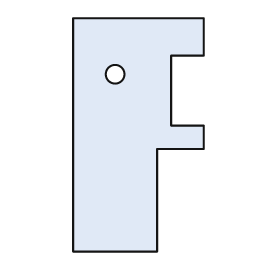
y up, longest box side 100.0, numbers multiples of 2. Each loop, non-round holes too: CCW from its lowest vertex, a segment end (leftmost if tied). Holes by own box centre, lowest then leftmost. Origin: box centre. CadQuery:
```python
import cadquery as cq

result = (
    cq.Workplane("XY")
    .moveTo(-28.0, -50.0)
    .lineTo(8.0, -50.0)
    .lineTo(8.0, -6.0)
    .lineTo(28.0, -6.0)
    .lineTo(28.0, 4.0)
    .lineTo(14.0, 4.0)
    .lineTo(14.0, 34.0)
    .lineTo(28.0, 34.0)
    .lineTo(28.0, 50.0)
    .lineTo(-28.0, 50.0)
    .close()
    .moveTo(-10.0, 26.0)
    .circle(4.0)
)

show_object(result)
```